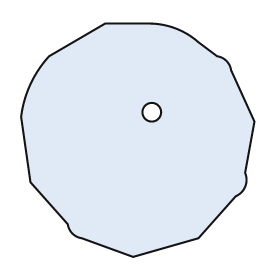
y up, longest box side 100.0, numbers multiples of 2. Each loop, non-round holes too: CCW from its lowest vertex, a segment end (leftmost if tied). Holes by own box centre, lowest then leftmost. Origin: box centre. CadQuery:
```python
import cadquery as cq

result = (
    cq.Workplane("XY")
    .moveTo(-2.0, -50.0)
    .lineTo(26.0, -42.0)
    .lineTo(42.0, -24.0)
    .threePointArc((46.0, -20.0), (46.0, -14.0))
    .lineTo(50.0, 8.0)
    .lineTo(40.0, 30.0)
    .threePointArc((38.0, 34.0), (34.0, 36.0))
    .lineTo(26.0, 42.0)
    .threePointArc((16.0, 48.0), (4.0, 50.0))
    .lineTo(-14.0, 50.0)
    .lineTo(-38.0, 36.0)
    .threePointArc((-46.0, 24.0), (-50.0, 10.0))
    .lineTo(-46.0, -18.0)
    .lineTo(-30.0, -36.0)
    .threePointArc((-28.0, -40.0), (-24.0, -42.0))
    .close()
    .moveTo(6.0, 12.0)
    .circle(4.0)
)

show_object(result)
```